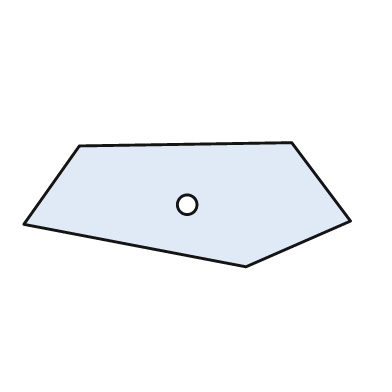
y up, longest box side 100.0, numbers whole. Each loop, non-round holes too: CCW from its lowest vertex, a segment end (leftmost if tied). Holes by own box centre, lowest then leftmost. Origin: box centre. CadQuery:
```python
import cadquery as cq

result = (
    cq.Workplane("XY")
    .moveTo(18.0, -19.0)
    .lineTo(50.0, -5.0)
    .lineTo(32.0, 19.0)
    .lineTo(-33.0, 18.0)
    .lineTo(-50.0, -6.0)
    .close()
    .moveTo(0.0, 0.0)
    .circle(3.0)
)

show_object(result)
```